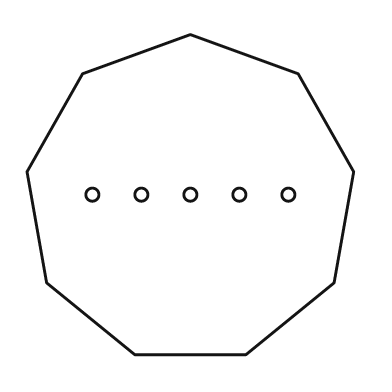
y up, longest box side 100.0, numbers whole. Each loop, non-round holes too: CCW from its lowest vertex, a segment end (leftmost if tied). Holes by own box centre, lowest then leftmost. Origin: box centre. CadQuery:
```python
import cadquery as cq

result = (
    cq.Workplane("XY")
    .moveTo(-17.0, -49.0)
    .lineTo(17.0, -49.0)
    .lineTo(44.0, -27.0)
    .lineTo(50.0, 7.0)
    .lineTo(33.0, 37.0)
    .lineTo(0.0, 49.0)
    .lineTo(-33.0, 37.0)
    .lineTo(-50.0, 7.0)
    .lineTo(-44.0, -27.0)
    .close()
    .moveTo(-30.0, 0.0)
    .circle(2.0)
    .moveTo(-15.0, 0.0)
    .circle(2.0)
    .moveTo(0.0, 0.0)
    .circle(2.0)
    .moveTo(15.0, 0.0)
    .circle(2.0)
    .moveTo(30.0, 0.0)
    .circle(2.0)
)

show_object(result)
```